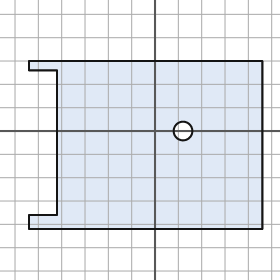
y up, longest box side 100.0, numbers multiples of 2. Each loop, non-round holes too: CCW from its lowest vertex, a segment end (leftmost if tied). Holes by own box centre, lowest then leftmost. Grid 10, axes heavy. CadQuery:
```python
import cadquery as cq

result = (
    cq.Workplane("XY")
    .moveTo(-54.0, -42.0)
    .lineTo(46.0, -42.0)
    .lineTo(46.0, 30.0)
    .lineTo(-54.0, 30.0)
    .lineTo(-54.0, 26.0)
    .lineTo(-42.0, 26.0)
    .lineTo(-42.0, -36.0)
    .lineTo(-54.0, -36.0)
    .close()
    .moveTo(12.0, 0.0)
    .circle(4.0)
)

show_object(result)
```